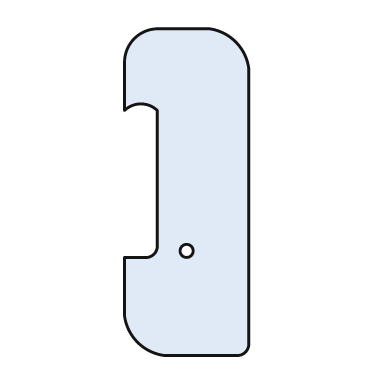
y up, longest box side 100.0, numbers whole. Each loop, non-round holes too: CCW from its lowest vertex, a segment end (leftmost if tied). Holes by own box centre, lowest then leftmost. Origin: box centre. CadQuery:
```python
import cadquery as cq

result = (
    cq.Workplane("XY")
    .moveTo(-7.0, -50.0)
    .lineTo(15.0, -50.0)
    .threePointArc((18.0, -49.0), (19.0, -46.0))
    .lineTo(19.0, 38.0)
    .threePointArc((15.0, 46.0), (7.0, 50.0))
    .lineTo(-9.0, 50.0)
    .threePointArc((-16.0, 47.0), (-19.0, 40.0))
    .lineTo(-19.0, 25.0)
    .threePointArc((-14.0, 27.0), (-9.0, 25.0))
    .lineTo(-9.0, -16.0)
    .threePointArc((-10.0, -19.0), (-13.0, -20.0))
    .lineTo(-19.0, -20.0)
    .lineTo(-19.0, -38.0)
    .threePointArc((-15.0, -46.0), (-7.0, -50.0))
    .close()
    .moveTo(0.0, -18.0)
    .circle(2.0)
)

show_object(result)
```